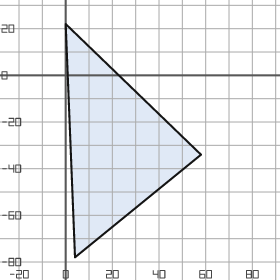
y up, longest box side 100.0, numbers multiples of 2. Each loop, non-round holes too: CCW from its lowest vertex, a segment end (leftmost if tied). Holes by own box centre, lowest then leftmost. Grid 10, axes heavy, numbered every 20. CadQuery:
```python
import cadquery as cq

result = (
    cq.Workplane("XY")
    .moveTo(4.0, -78.0)
    .lineTo(58.0, -34.0)
    .lineTo(0.0, 22.0)
    .close()
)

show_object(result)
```